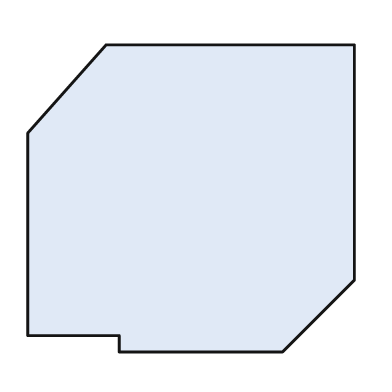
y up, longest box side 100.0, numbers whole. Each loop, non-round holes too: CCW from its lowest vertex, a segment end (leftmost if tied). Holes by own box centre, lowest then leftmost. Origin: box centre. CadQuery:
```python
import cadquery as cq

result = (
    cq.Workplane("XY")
    .moveTo(-22.0, -47.0)
    .lineTo(28.0, -47.0)
    .lineTo(50.0, -25.0)
    .lineTo(50.0, 47.0)
    .lineTo(-26.0, 47.0)
    .lineTo(-50.0, 20.0)
    .lineTo(-50.0, -42.0)
    .lineTo(-22.0, -42.0)
    .close()
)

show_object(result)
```